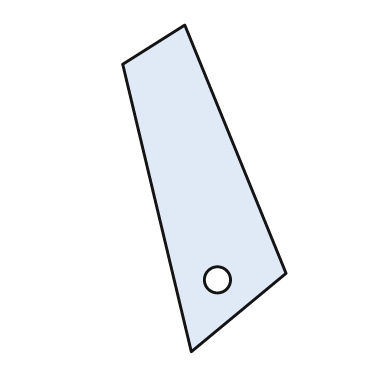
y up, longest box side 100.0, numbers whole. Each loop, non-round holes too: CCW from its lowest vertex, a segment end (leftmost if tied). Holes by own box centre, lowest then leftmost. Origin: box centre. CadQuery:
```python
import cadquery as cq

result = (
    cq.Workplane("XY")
    .moveTo(-4.0, -50.0)
    .lineTo(25.0, -26.0)
    .lineTo(-6.0, 50.0)
    .lineTo(-25.0, 38.0)
    .close()
    .moveTo(4.0, -28.0)
    .circle(4.0)
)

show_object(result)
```